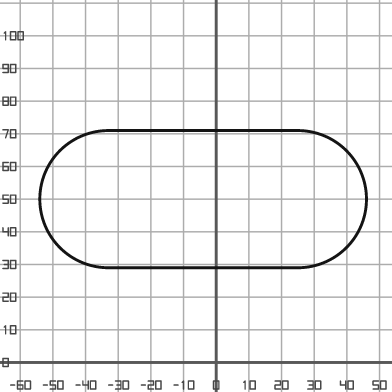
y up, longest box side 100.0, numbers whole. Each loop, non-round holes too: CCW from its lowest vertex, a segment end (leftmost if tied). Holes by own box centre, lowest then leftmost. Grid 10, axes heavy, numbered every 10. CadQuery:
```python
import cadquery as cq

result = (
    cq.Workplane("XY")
    .moveTo(-33.0, 29.0)
    .lineTo(25.0, 29.0)
    .threePointArc((46.0, 50.0), (25.0, 71.0))
    .lineTo(-33.0, 71.0)
    .threePointArc((-54.0, 50.0), (-33.0, 29.0))
    .close()
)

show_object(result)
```